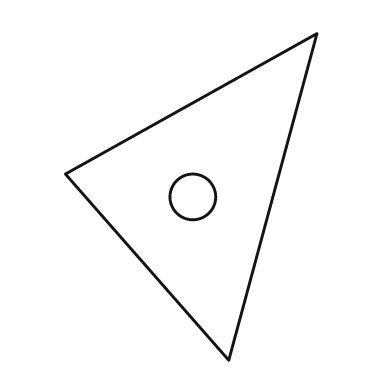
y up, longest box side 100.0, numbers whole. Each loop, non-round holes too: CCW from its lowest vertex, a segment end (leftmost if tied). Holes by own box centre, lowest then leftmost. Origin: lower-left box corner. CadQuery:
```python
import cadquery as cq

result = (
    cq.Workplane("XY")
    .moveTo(50.0, 0.0)
    .lineTo(77.0, 100.0)
    .lineTo(0.0, 57.0)
    .close()
    .moveTo(39.0, 50.0)
    .circle(7.0)
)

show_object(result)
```